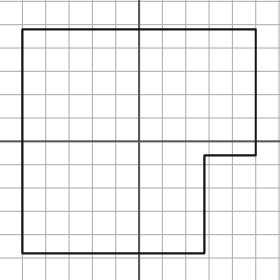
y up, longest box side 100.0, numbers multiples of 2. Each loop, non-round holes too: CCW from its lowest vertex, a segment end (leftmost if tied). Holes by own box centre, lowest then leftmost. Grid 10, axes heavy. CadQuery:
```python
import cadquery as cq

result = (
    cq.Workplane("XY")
    .moveTo(-50.0, -48.0)
    .lineTo(28.0, -48.0)
    .lineTo(28.0, -6.0)
    .lineTo(50.0, -6.0)
    .lineTo(50.0, 48.0)
    .lineTo(-50.0, 48.0)
    .close()
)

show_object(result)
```